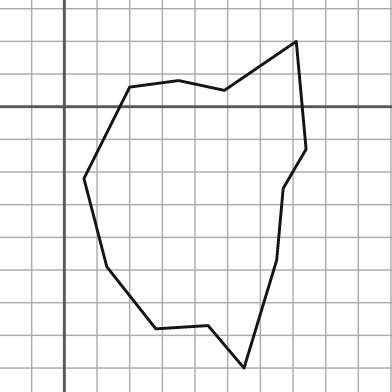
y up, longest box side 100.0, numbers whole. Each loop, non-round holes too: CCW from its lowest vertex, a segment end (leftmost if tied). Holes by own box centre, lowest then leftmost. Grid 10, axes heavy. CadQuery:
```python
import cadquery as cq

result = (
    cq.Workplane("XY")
    .moveTo(55.0, -80.0)
    .lineTo(65.0, -47.0)
    .lineTo(67.0, -25.0)
    .lineTo(74.0, -13.0)
    .lineTo(71.0, 20.0)
    .lineTo(49.0, 5.0)
    .lineTo(35.0, 8.0)
    .lineTo(20.0, 6.0)
    .lineTo(6.0, -22.0)
    .lineTo(13.0, -49.0)
    .lineTo(28.0, -68.0)
    .lineTo(44.0, -67.0)
    .close()
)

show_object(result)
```